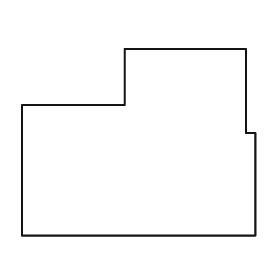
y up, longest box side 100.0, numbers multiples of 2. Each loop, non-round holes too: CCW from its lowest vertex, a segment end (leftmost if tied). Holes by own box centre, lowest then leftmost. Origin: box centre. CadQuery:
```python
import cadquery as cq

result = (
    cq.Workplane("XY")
    .moveTo(-50.0, -40.0)
    .lineTo(50.0, -40.0)
    .lineTo(50.0, 4.0)
    .lineTo(46.0, 4.0)
    .lineTo(46.0, 40.0)
    .lineTo(-6.0, 40.0)
    .lineTo(-6.0, 16.0)
    .lineTo(-50.0, 16.0)
    .close()
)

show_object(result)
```